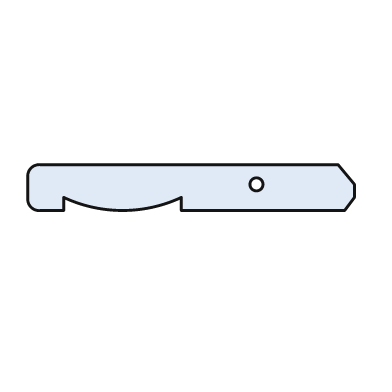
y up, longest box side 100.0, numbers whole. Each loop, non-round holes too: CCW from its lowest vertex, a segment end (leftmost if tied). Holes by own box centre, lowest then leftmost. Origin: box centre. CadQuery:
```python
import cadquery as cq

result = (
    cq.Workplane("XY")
    .moveTo(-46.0, -7.0)
    .lineTo(-39.0, -7.0)
    .lineTo(-39.0, -3.0)
    .threePointArc((-21.0, -7.0), (-3.0, -3.0))
    .lineTo(-3.0, -7.0)
    .lineTo(47.0, -7.0)
    .lineTo(50.0, -3.0)
    .lineTo(50.0, 1.0)
    .lineTo(45.0, 7.0)
    .lineTo(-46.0, 7.0)
    .threePointArc((-49.0, 6.0), (-50.0, 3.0))
    .lineTo(-50.0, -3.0)
    .threePointArc((-49.0, -6.0), (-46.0, -7.0))
    .close()
    .moveTo(20.0, 1.0)
    .circle(2.0)
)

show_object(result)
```